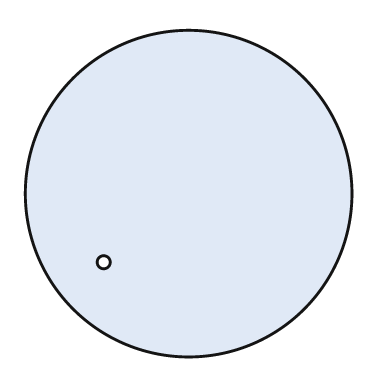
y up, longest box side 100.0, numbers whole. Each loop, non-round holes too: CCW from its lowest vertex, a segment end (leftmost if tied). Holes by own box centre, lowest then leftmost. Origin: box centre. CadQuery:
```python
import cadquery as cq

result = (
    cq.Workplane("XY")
    .moveTo(0.0, 0.0)
    .circle(50.0)
    .moveTo(-26.0, -21.0)
    .circle(2.0)
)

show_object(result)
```